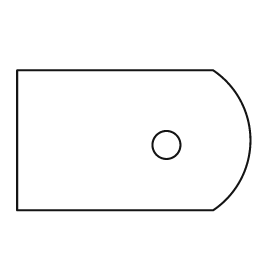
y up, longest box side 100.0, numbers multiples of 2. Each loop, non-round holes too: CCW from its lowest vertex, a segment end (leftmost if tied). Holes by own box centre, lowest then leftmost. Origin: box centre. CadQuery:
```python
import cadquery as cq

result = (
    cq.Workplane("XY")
    .moveTo(-50.0, -30.0)
    .lineTo(34.0, -30.0)
    .threePointArc((50.0, 0.0), (34.0, 30.0))
    .lineTo(-50.0, 30.0)
    .close()
    .moveTo(14.0, -2.0)
    .circle(6.0)
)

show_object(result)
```